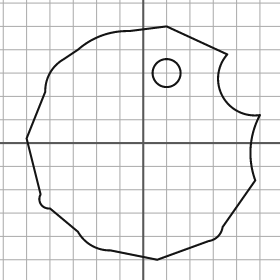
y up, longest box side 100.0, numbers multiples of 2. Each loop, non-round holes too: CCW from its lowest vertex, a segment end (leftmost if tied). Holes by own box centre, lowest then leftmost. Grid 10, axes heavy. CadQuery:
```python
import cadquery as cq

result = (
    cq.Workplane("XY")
    .moveTo(6.0, -50.0)
    .lineTo(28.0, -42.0)
    .threePointArc((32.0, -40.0), (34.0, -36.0))
    .lineTo(48.0, -16.0)
    .threePointArc((46.0, -2.0), (50.0, 12.0))
    .threePointArc((34.0, 20.0), (36.0, 38.0))
    .lineTo(10.0, 50.0)
    .lineTo(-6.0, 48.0)
    .threePointArc((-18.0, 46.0), (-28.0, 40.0))
    .lineTo(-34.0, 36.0)
    .threePointArc((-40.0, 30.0), (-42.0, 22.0))
    .lineTo(-50.0, 2.0)
    .lineTo(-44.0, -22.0)
    .threePointArc((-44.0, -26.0), (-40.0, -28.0))
    .lineTo(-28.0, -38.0)
    .threePointArc((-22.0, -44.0), (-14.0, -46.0))
    .close()
    .moveTo(10.0, 30.0)
    .circle(6.0)
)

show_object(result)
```